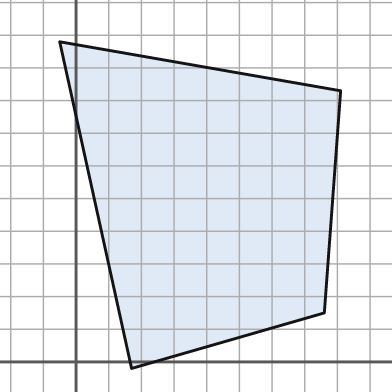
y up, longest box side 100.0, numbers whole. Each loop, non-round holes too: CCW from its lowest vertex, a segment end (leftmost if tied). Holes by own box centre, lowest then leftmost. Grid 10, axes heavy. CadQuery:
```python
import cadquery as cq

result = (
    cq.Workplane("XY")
    .moveTo(17.0, -2.0)
    .lineTo(76.0, 15.0)
    .lineTo(81.0, 83.0)
    .lineTo(-5.0, 98.0)
    .close()
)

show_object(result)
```